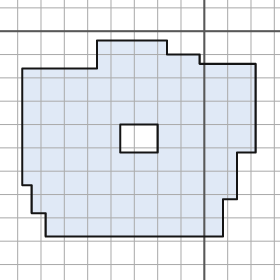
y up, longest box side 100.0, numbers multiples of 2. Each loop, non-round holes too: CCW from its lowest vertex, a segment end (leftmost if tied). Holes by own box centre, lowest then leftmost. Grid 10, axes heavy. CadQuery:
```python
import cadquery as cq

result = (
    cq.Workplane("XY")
    .moveTo(-68.0, -88.0)
    .lineTo(8.0, -88.0)
    .lineTo(8.0, -72.0)
    .lineTo(14.0, -72.0)
    .lineTo(14.0, -52.0)
    .lineTo(22.0, -52.0)
    .lineTo(22.0, -14.0)
    .lineTo(-2.0, -14.0)
    .lineTo(-2.0, -10.0)
    .lineTo(-16.0, -10.0)
    .lineTo(-16.0, -4.0)
    .lineTo(-46.0, -4.0)
    .lineTo(-46.0, -16.0)
    .lineTo(-78.0, -16.0)
    .lineTo(-78.0, -66.0)
    .lineTo(-74.0, -66.0)
    .lineTo(-74.0, -78.0)
    .lineTo(-68.0, -78.0)
    .close()
    .moveTo(-36.0, -52.0)
    .lineTo(-20.0, -52.0)
    .lineTo(-20.0, -40.0)
    .lineTo(-36.0, -40.0)
    .close()
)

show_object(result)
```